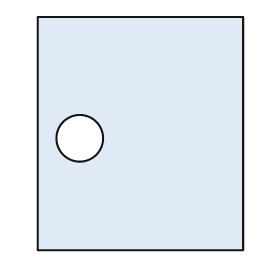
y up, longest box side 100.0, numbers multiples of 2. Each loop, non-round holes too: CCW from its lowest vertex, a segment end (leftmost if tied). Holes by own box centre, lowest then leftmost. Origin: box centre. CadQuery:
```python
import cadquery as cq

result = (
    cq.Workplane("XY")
    .moveTo(-44.0, -50.0)
    .lineTo(44.0, -50.0)
    .lineTo(44.0, 50.0)
    .lineTo(-44.0, 50.0)
    .close()
    .moveTo(-26.0, -2.0)
    .circle(10.0)
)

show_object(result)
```